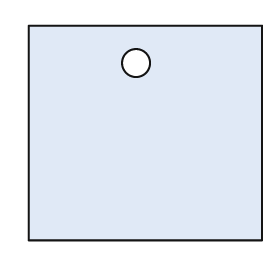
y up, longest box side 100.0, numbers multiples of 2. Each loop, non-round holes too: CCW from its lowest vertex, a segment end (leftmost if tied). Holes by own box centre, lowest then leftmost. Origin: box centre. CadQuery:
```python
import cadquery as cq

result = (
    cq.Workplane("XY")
    .moveTo(-50.0, -46.0)
    .lineTo(50.0, -46.0)
    .lineTo(50.0, 46.0)
    .lineTo(-50.0, 46.0)
    .close()
    .moveTo(-4.0, 30.0)
    .circle(6.0)
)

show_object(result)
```